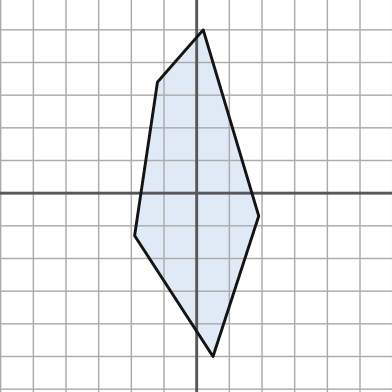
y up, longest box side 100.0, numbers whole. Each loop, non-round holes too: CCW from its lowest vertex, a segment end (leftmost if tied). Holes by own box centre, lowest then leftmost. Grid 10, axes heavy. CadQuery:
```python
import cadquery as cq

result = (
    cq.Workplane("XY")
    .moveTo(5.0, -50.0)
    .lineTo(19.0, -7.0)
    .lineTo(2.0, 50.0)
    .lineTo(-12.0, 34.0)
    .lineTo(-19.0, -13.0)
    .close()
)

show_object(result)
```